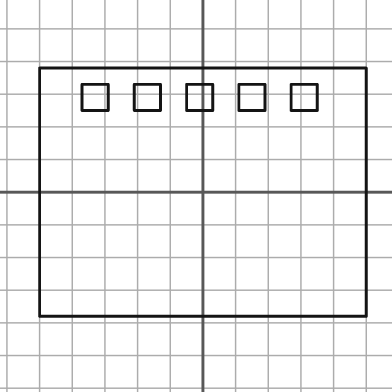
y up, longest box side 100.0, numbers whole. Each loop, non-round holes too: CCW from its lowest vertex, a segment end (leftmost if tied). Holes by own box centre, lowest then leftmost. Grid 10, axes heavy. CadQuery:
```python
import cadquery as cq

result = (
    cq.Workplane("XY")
    .moveTo(-50.0, -38.0)
    .lineTo(50.0, -38.0)
    .lineTo(50.0, 38.0)
    .lineTo(-50.0, 38.0)
    .close()
    .moveTo(-37.0, 25.0)
    .lineTo(-29.0, 25.0)
    .lineTo(-29.0, 33.0)
    .lineTo(-37.0, 33.0)
    .close()
    .moveTo(-21.0, 25.0)
    .lineTo(-13.0, 25.0)
    .lineTo(-13.0, 33.0)
    .lineTo(-21.0, 33.0)
    .close()
    .moveTo(-5.0, 25.0)
    .lineTo(3.0, 25.0)
    .lineTo(3.0, 33.0)
    .lineTo(-5.0, 33.0)
    .close()
    .moveTo(11.0, 25.0)
    .lineTo(19.0, 25.0)
    .lineTo(19.0, 33.0)
    .lineTo(11.0, 33.0)
    .close()
    .moveTo(27.0, 25.0)
    .lineTo(35.0, 25.0)
    .lineTo(35.0, 33.0)
    .lineTo(27.0, 33.0)
    .close()
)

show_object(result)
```